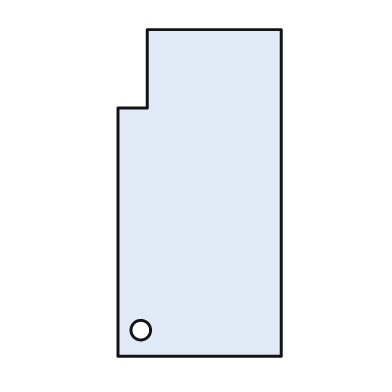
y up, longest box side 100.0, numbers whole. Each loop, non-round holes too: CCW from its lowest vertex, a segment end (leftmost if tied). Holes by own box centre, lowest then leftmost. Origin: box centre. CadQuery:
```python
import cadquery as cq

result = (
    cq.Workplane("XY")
    .moveTo(-25.0, -50.0)
    .lineTo(25.0, -50.0)
    .lineTo(25.0, 50.0)
    .lineTo(-16.0, 50.0)
    .lineTo(-16.0, 26.0)
    .lineTo(-25.0, 26.0)
    .close()
    .moveTo(-18.0, -42.0)
    .circle(3.0)
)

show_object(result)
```